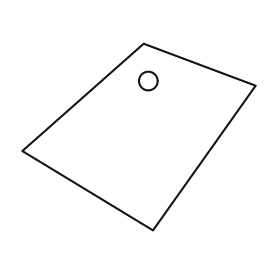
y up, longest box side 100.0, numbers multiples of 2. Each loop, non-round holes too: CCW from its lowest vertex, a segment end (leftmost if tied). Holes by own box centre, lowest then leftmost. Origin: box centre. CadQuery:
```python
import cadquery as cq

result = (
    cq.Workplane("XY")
    .moveTo(6.0, -40.0)
    .lineTo(50.0, 22.0)
    .lineTo(2.0, 40.0)
    .lineTo(-50.0, -6.0)
    .close()
    .moveTo(4.0, 24.0)
    .circle(4.0)
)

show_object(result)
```